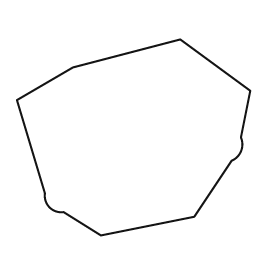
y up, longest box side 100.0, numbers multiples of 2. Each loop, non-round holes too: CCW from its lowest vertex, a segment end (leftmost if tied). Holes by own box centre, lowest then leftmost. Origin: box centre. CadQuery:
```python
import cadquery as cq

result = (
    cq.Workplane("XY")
    .moveTo(-14.0, -42.0)
    .lineTo(26.0, -34.0)
    .lineTo(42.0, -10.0)
    .threePointArc((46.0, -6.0), (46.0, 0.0))
    .lineTo(50.0, 20.0)
    .lineTo(20.0, 42.0)
    .lineTo(-26.0, 30.0)
    .lineTo(-50.0, 16.0)
    .lineTo(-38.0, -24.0)
    .threePointArc((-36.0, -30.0), (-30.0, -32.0))
    .close()
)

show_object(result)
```